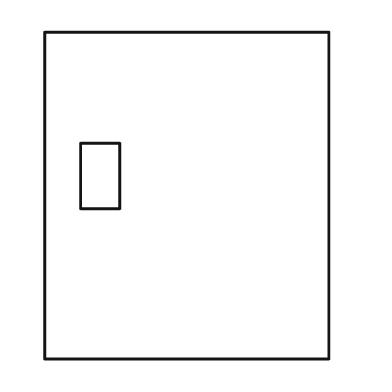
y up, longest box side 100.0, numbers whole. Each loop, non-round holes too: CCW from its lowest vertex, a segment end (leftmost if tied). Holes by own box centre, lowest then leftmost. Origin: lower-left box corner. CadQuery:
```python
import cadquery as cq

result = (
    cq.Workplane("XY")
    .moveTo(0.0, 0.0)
    .lineTo(87.0, 0.0)
    .lineTo(87.0, 100.0)
    .lineTo(0.0, 100.0)
    .close()
    .moveTo(11.0, 46.0)
    .lineTo(23.0, 46.0)
    .lineTo(23.0, 66.0)
    .lineTo(11.0, 66.0)
    .close()
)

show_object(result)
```